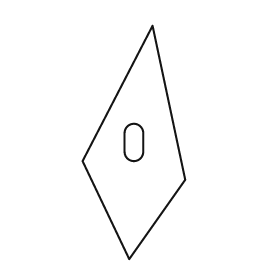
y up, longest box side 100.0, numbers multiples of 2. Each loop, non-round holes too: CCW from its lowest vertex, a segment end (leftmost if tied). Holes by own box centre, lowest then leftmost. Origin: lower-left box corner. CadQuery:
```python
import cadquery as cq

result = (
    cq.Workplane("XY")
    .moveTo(20.0, 0.0)
    .lineTo(44.0, 34.0)
    .lineTo(30.0, 100.0)
    .lineTo(0.0, 42.0)
    .close()
    .moveTo(18.0, 46.0)
    .threePointArc((22.0, 42.0), (26.0, 46.0))
    .lineTo(26.0, 54.0)
    .threePointArc((22.0, 58.0), (18.0, 54.0))
    .close()
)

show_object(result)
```